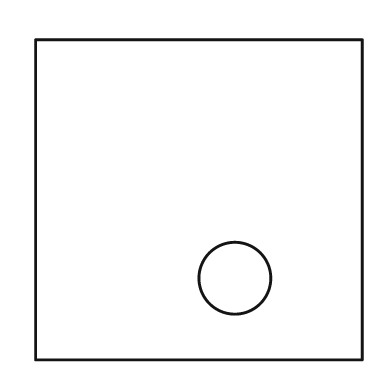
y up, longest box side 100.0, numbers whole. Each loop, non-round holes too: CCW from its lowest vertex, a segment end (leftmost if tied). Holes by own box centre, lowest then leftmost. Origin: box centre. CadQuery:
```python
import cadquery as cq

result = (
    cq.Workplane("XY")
    .moveTo(-50.0, -49.0)
    .lineTo(50.0, -49.0)
    .lineTo(50.0, 49.0)
    .lineTo(-50.0, 49.0)
    .close()
    .moveTo(11.0, -24.0)
    .circle(11.0)
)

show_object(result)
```